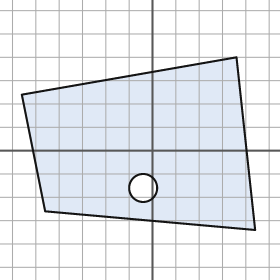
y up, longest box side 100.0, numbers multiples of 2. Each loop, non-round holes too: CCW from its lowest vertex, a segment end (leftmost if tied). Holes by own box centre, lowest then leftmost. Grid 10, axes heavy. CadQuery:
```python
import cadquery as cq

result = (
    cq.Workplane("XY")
    .moveTo(44.0, -34.0)
    .lineTo(36.0, 40.0)
    .lineTo(-56.0, 24.0)
    .lineTo(-46.0, -26.0)
    .close()
    .moveTo(-4.0, -16.0)
    .circle(6.0)
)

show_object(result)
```